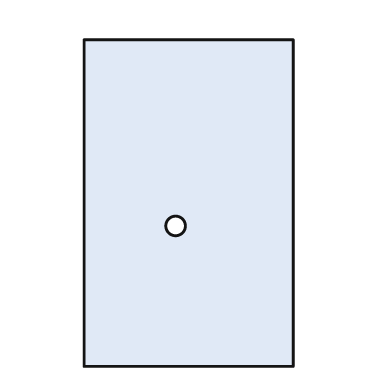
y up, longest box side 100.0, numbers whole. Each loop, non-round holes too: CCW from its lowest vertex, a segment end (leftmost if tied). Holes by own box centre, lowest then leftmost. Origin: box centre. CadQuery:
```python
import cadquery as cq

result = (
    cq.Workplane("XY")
    .moveTo(-32.0, -50.0)
    .lineTo(32.0, -50.0)
    .lineTo(32.0, 50.0)
    .lineTo(-32.0, 50.0)
    .close()
    .moveTo(-4.0, -7.0)
    .circle(3.0)
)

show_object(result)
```